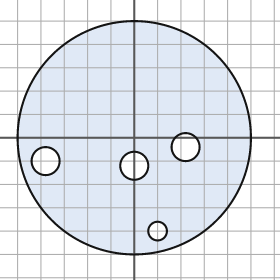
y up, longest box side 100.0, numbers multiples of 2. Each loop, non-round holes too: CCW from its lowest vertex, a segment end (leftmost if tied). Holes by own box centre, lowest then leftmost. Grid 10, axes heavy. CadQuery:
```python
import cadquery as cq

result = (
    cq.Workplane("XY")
    .moveTo(0.0, 0.0)
    .circle(50.0)
    .moveTo(10.0, -40.0)
    .circle(4.0)
    .moveTo(0.0, -12.0)
    .circle(6.0)
    .moveTo(-38.0, -10.0)
    .circle(6.0)
    .moveTo(22.0, -4.0)
    .circle(6.0)
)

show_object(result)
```